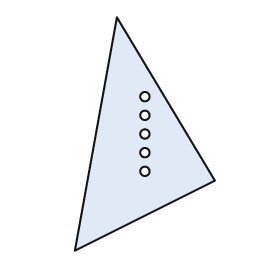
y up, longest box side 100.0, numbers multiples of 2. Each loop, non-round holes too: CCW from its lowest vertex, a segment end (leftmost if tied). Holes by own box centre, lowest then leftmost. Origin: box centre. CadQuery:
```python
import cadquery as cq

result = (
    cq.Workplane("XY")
    .moveTo(-30.0, -50.0)
    .lineTo(30.0, -20.0)
    .lineTo(-12.0, 50.0)
    .close()
    .moveTo(0.0, -16.0)
    .circle(2.0)
    .moveTo(0.0, -8.0)
    .circle(2.0)
    .moveTo(0.0, 0.0)
    .circle(2.0)
    .moveTo(0.0, 8.0)
    .circle(2.0)
    .moveTo(0.0, 16.0)
    .circle(2.0)
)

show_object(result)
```